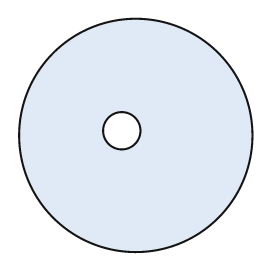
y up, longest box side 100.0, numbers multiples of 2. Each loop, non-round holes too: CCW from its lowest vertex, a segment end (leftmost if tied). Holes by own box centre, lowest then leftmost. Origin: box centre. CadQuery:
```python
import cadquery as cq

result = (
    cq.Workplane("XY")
    .moveTo(0.0, 0.0)
    .circle(50.0)
    .moveTo(-6.0, 2.0)
    .circle(8.0)
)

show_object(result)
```